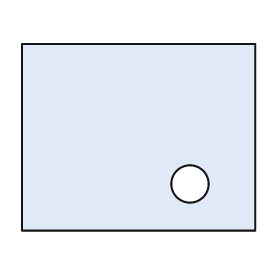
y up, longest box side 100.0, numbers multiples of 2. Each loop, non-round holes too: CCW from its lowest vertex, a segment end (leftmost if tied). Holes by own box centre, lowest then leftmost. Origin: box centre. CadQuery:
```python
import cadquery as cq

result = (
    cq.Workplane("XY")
    .moveTo(-50.0, -40.0)
    .lineTo(50.0, -40.0)
    .lineTo(50.0, 40.0)
    .lineTo(-50.0, 40.0)
    .close()
    .moveTo(22.0, -20.0)
    .circle(8.0)
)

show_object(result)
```